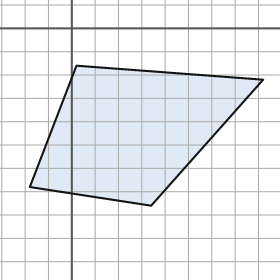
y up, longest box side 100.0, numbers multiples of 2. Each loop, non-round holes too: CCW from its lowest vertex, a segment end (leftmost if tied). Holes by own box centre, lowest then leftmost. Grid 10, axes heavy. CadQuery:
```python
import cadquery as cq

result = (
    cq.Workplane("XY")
    .moveTo(34.0, -76.0)
    .lineTo(82.0, -22.0)
    .lineTo(2.0, -16.0)
    .lineTo(-18.0, -68.0)
    .close()
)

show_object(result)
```